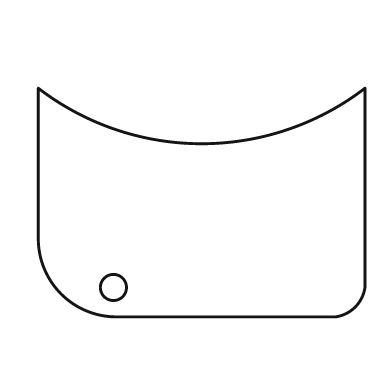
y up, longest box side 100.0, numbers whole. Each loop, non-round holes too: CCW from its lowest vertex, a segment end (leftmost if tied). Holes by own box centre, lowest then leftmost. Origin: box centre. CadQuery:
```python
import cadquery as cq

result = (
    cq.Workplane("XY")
    .moveTo(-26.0, -35.0)
    .lineTo(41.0, -35.0)
    .threePointArc((47.0, -32.0), (50.0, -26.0))
    .lineTo(50.0, 35.0)
    .threePointArc((0.0, 18.0), (-50.0, 35.0))
    .lineTo(-50.0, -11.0)
    .threePointArc((-43.0, -28.0), (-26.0, -35.0))
    .close()
    .moveTo(-27.0, -26.0)
    .circle(4.0)
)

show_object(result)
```